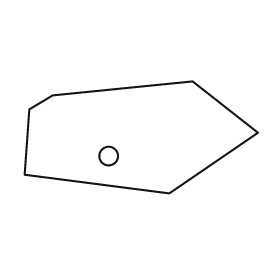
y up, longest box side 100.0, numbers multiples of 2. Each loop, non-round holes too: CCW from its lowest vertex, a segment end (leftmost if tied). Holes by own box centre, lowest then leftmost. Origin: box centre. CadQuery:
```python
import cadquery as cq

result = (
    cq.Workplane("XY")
    .moveTo(12.0, -24.0)
    .lineTo(50.0, 2.0)
    .lineTo(22.0, 24.0)
    .lineTo(-38.0, 18.0)
    .lineTo(-48.0, 12.0)
    .lineTo(-50.0, -16.0)
    .close()
    .moveTo(-14.0, -8.0)
    .circle(4.0)
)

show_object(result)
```